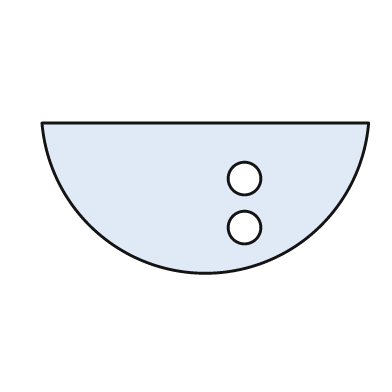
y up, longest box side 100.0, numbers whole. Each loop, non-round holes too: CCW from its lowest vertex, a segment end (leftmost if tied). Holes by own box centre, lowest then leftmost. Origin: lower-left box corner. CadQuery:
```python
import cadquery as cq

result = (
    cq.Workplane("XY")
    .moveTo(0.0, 46.0)
    .threePointArc((50.0, 0.0), (100.0, 46.0))
    .close()
    .moveTo(62.0, 14.0)
    .circle(5.0)
    .moveTo(62.0, 29.0)
    .circle(5.0)
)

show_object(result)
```